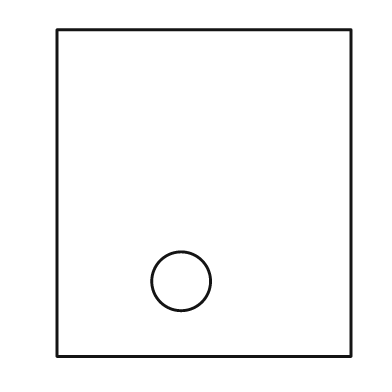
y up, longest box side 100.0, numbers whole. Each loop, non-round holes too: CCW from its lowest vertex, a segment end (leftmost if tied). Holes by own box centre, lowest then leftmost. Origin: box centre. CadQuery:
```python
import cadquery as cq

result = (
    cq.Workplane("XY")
    .moveTo(-45.0, -50.0)
    .lineTo(45.0, -50.0)
    .lineTo(45.0, 50.0)
    .lineTo(-45.0, 50.0)
    .close()
    .moveTo(-7.0, -27.0)
    .circle(9.0)
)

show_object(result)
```